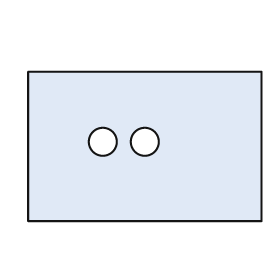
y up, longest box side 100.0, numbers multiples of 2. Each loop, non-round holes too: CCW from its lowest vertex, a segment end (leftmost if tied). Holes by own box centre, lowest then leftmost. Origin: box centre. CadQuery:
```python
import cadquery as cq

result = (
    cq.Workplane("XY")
    .moveTo(-50.0, -32.0)
    .lineTo(50.0, -32.0)
    .lineTo(50.0, 32.0)
    .lineTo(-50.0, 32.0)
    .close()
    .moveTo(-18.0, 2.0)
    .circle(6.0)
    .moveTo(0.0, 2.0)
    .circle(6.0)
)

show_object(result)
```